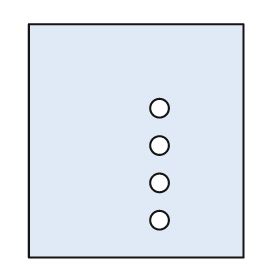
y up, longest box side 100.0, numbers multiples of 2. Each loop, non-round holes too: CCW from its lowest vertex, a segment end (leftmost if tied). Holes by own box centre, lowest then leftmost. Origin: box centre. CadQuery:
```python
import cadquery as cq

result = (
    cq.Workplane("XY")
    .moveTo(-46.0, -50.0)
    .lineTo(46.0, -50.0)
    .lineTo(46.0, 50.0)
    .lineTo(-46.0, 50.0)
    .close()
    .moveTo(10.0, -34.0)
    .circle(4.0)
    .moveTo(10.0, -18.0)
    .circle(4.0)
    .moveTo(10.0, -2.0)
    .circle(4.0)
    .moveTo(10.0, 14.0)
    .circle(4.0)
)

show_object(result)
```